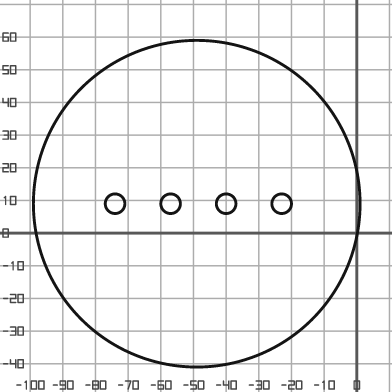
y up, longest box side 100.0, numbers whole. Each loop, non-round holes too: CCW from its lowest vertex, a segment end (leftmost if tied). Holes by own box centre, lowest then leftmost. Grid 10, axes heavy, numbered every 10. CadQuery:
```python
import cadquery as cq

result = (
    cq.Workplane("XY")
    .moveTo(-49.0, 9.0)
    .circle(50.0)
    .moveTo(-74.0, 9.0)
    .circle(3.0)
    .moveTo(-57.0, 9.0)
    .circle(3.0)
    .moveTo(-40.0, 9.0)
    .circle(3.0)
    .moveTo(-23.0, 9.0)
    .circle(3.0)
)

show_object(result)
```